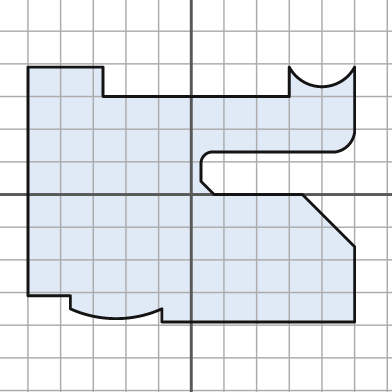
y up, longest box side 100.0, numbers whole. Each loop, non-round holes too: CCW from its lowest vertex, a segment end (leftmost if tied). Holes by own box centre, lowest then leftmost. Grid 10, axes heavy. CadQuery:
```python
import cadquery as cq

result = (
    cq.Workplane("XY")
    .moveTo(-9.0, -39.0)
    .lineTo(50.0, -39.0)
    .lineTo(50.0, -16.0)
    .lineTo(34.0, 0.0)
    .lineTo(7.0, 0.0)
    .lineTo(3.0, 4.0)
    .lineTo(3.0, 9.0)
    .threePointArc((4.0, 12.0), (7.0, 13.0))
    .lineTo(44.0, 13.0)
    .threePointArc((48.0, 15.0), (50.0, 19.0))
    .lineTo(50.0, 39.0)
    .threePointArc((40.0, 33.0), (30.0, 39.0))
    .lineTo(30.0, 30.0)
    .lineTo(-27.0, 30.0)
    .lineTo(-27.0, 39.0)
    .lineTo(-50.0, 39.0)
    .lineTo(-50.0, -31.0)
    .lineTo(-37.0, -31.0)
    .lineTo(-37.0, -35.0)
    .threePointArc((-23.0, -38.0), (-9.0, -35.0))
    .close()
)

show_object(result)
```